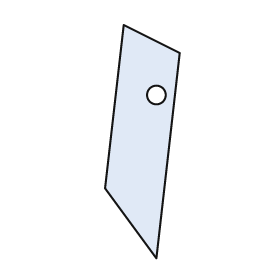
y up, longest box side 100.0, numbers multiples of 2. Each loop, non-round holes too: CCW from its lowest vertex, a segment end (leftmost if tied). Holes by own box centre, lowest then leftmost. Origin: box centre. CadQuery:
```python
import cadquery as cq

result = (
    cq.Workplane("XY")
    .moveTo(6.0, -50.0)
    .lineTo(16.0, 38.0)
    .lineTo(-8.0, 50.0)
    .lineTo(-16.0, -20.0)
    .close()
    .moveTo(6.0, 20.0)
    .circle(4.0)
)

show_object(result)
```